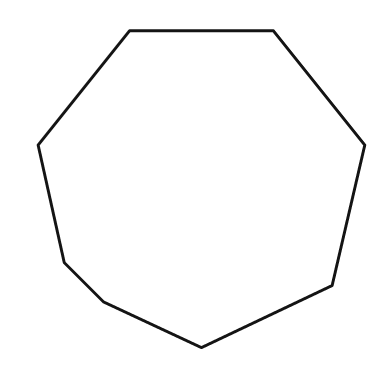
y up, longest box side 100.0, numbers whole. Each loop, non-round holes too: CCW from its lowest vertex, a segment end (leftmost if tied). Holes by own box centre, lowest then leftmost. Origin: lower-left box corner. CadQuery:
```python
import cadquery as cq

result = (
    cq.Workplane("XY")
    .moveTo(50.0, 0.0)
    .lineTo(90.0, 19.0)
    .lineTo(100.0, 62.0)
    .lineTo(72.0, 97.0)
    .lineTo(28.0, 97.0)
    .lineTo(0.0, 62.0)
    .lineTo(8.0, 26.0)
    .lineTo(20.0, 14.0)
    .close()
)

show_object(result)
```